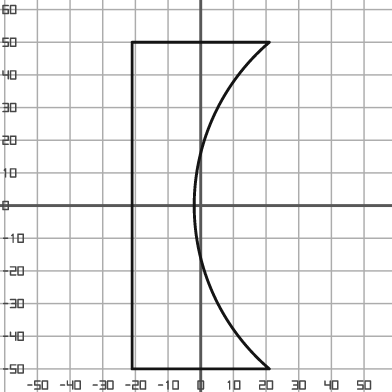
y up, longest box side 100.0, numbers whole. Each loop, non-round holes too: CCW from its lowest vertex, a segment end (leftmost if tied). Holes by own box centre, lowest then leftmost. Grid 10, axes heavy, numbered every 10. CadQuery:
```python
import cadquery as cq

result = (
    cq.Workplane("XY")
    .moveTo(-21.0, -50.0)
    .lineTo(21.0, -50.0)
    .threePointArc((-2.0, 0.0), (21.0, 50.0))
    .lineTo(-21.0, 50.0)
    .close()
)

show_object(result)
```